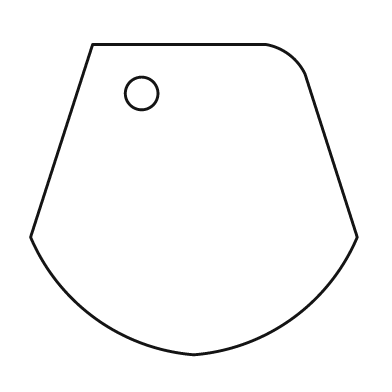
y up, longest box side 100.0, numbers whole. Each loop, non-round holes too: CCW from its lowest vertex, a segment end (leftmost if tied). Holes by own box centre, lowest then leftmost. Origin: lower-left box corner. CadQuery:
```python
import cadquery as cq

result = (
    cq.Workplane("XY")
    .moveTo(50.0, 0.0)
    .threePointArc((80.0, 11.0), (100.0, 36.0))
    .lineTo(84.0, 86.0)
    .threePointArc((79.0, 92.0), (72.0, 95.0))
    .lineTo(19.0, 95.0)
    .lineTo(0.0, 36.0)
    .threePointArc((20.0, 11.0), (50.0, 0.0))
    .close()
    .moveTo(34.0, 80.0)
    .circle(5.0)
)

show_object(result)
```